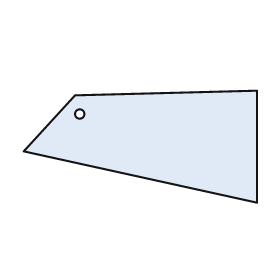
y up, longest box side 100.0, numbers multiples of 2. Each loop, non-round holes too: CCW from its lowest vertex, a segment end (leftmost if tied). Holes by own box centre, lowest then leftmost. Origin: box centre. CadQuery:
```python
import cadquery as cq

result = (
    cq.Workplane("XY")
    .moveTo(50.0, -24.0)
    .lineTo(50.0, 24.0)
    .lineTo(-28.0, 22.0)
    .lineTo(-50.0, -2.0)
    .close()
    .moveTo(-26.0, 14.0)
    .circle(2.0)
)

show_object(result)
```